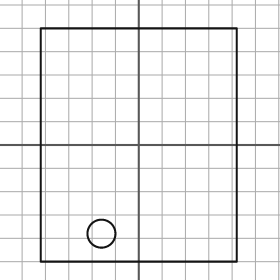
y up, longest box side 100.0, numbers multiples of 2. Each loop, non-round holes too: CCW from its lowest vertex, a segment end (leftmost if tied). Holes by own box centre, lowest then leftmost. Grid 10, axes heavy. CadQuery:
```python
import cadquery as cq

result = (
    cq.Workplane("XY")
    .moveTo(-42.0, -50.0)
    .lineTo(42.0, -50.0)
    .lineTo(42.0, 50.0)
    .lineTo(-42.0, 50.0)
    .close()
    .moveTo(-16.0, -38.0)
    .circle(6.0)
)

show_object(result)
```